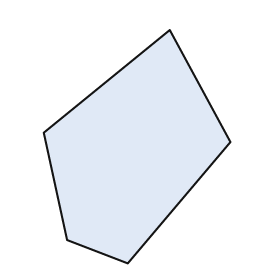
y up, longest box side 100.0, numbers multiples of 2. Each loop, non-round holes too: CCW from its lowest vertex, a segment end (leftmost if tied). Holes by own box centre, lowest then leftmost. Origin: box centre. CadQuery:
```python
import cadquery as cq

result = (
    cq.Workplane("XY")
    .moveTo(-4.0, -50.0)
    .lineTo(40.0, 2.0)
    .lineTo(14.0, 50.0)
    .lineTo(-40.0, 6.0)
    .lineTo(-30.0, -40.0)
    .close()
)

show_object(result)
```